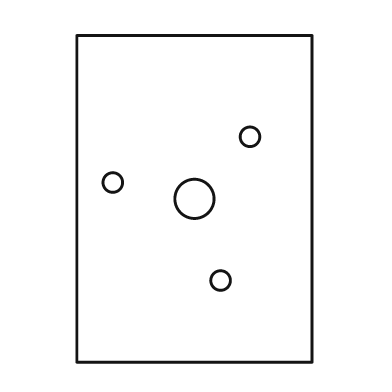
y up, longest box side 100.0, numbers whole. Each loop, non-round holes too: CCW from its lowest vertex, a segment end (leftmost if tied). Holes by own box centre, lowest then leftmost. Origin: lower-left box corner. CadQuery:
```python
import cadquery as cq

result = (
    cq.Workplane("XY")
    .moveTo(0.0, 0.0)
    .lineTo(72.0, 0.0)
    .lineTo(72.0, 100.0)
    .lineTo(0.0, 100.0)
    .close()
    .moveTo(44.0, 25.0)
    .circle(3.0)
    .moveTo(36.0, 50.0)
    .circle(6.0)
    .moveTo(11.0, 55.0)
    .circle(3.0)
    .moveTo(53.0, 69.0)
    .circle(3.0)
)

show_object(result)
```